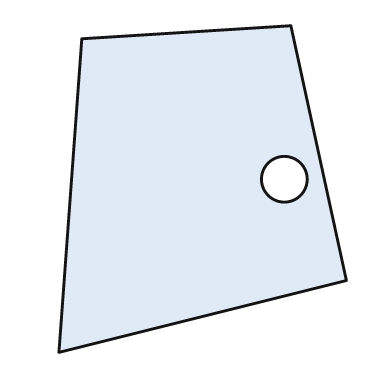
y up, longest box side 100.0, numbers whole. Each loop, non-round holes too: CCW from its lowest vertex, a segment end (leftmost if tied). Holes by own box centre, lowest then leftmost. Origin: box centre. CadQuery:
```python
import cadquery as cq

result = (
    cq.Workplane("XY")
    .moveTo(-44.0, -50.0)
    .lineTo(44.0, -28.0)
    .lineTo(27.0, 50.0)
    .lineTo(-37.0, 46.0)
    .close()
    .moveTo(25.0, 3.0)
    .circle(7.0)
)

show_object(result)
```